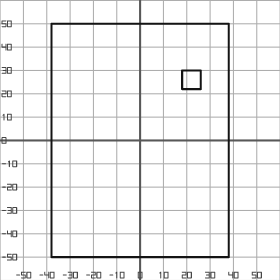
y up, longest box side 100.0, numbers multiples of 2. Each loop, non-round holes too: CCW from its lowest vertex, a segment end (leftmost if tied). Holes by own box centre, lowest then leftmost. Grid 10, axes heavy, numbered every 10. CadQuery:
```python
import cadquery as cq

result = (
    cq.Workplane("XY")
    .moveTo(-38.0, -50.0)
    .lineTo(38.0, -50.0)
    .lineTo(38.0, 50.0)
    .lineTo(-38.0, 50.0)
    .close()
    .moveTo(18.0, 22.0)
    .lineTo(26.0, 22.0)
    .lineTo(26.0, 30.0)
    .lineTo(18.0, 30.0)
    .close()
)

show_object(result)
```